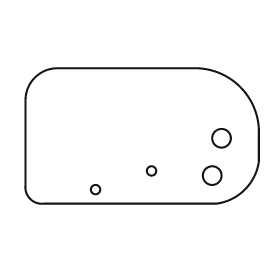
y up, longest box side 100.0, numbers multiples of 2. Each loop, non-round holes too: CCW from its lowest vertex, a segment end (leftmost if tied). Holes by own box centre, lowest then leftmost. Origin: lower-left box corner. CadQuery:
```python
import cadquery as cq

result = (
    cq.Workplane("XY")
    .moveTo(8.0, 0.0)
    .lineTo(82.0, 0.0)
    .threePointArc((94.0, 6.0), (100.0, 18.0))
    .lineTo(100.0, 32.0)
    .threePointArc((92.0, 50.0), (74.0, 58.0))
    .lineTo(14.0, 58.0)
    .threePointArc((4.0, 54.0), (0.0, 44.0))
    .lineTo(0.0, 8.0)
    .threePointArc((2.0, 2.0), (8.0, 0.0))
    .close()
    .moveTo(30.0, 6.0)
    .circle(2.0)
    .moveTo(80.0, 12.0)
    .circle(4.0)
    .moveTo(54.0, 14.0)
    .circle(2.0)
    .moveTo(84.0, 28.0)
    .circle(4.0)
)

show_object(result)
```